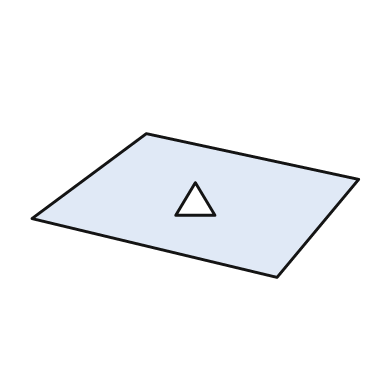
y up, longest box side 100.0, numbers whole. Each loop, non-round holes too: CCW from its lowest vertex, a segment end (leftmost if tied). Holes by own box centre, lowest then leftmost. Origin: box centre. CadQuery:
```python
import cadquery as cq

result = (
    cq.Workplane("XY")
    .moveTo(25.0, -22.0)
    .lineTo(50.0, 8.0)
    .lineTo(-15.0, 22.0)
    .lineTo(-50.0, -4.0)
    .close()
    .moveTo(-6.0, -3.0)
    .lineTo(6.0, -3.0)
    .lineTo(0.0, 7.0)
    .close()
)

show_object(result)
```